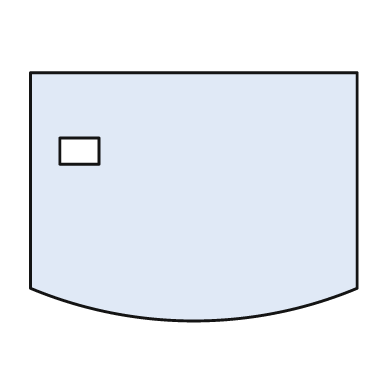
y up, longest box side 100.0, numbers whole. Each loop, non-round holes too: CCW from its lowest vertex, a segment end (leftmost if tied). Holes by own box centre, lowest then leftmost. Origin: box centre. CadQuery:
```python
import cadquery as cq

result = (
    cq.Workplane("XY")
    .moveTo(-50.0, -28.0)
    .threePointArc((0.0, -38.0), (50.0, -28.0))
    .lineTo(50.0, 38.0)
    .lineTo(-50.0, 38.0)
    .close()
    .moveTo(-41.0, 10.0)
    .lineTo(-29.0, 10.0)
    .lineTo(-29.0, 18.0)
    .lineTo(-41.0, 18.0)
    .close()
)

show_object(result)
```